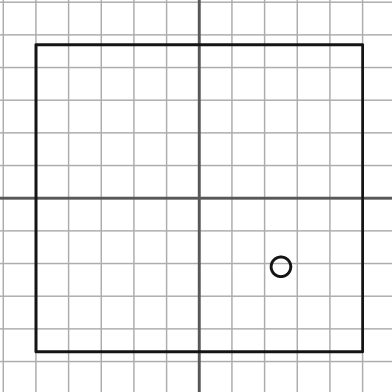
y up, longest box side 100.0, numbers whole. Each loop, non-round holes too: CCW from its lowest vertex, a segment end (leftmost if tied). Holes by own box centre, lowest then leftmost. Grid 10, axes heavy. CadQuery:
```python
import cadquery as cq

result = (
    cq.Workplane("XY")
    .moveTo(-50.0, -47.0)
    .lineTo(50.0, -47.0)
    .lineTo(50.0, 47.0)
    .lineTo(-50.0, 47.0)
    .close()
    .moveTo(25.0, -21.0)
    .circle(3.0)
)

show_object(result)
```